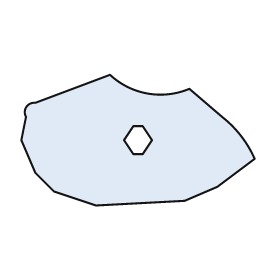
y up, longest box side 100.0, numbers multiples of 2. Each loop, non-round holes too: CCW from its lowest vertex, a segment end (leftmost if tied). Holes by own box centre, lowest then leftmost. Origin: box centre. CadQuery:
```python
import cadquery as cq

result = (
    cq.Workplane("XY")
    .moveTo(-18.0, -28.0)
    .lineTo(20.0, -26.0)
    .lineTo(34.0, -20.0)
    .lineTo(50.0, -8.0)
    .threePointArc((44.0, 2.0), (36.0, 10.0))
    .lineTo(22.0, 22.0)
    .threePointArc((4.0, 20.0), (-12.0, 28.0))
    .lineTo(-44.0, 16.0)
    .threePointArc((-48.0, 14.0), (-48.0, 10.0))
    .lineTo(-50.0, 0.0)
    .lineTo(-44.0, -14.0)
    .lineTo(-36.0, -22.0)
    .close()
    .moveTo(-2.0, -6.0)
    .lineTo(2.0, -6.0)
    .lineTo(6.0, 0.0)
    .lineTo(2.0, 6.0)
    .lineTo(-2.0, 6.0)
    .lineTo(-6.0, 0.0)
    .close()
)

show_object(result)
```